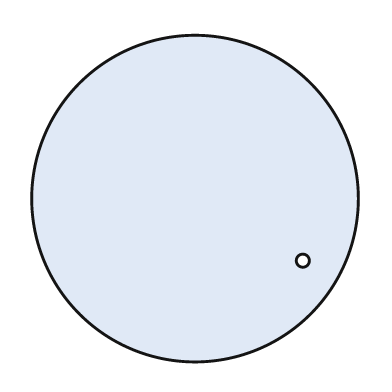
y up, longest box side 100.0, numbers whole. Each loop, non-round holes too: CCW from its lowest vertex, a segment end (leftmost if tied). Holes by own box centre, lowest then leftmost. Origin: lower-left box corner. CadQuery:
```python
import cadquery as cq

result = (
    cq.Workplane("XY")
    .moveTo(50.0, 50.0)
    .circle(50.0)
    .moveTo(83.0, 31.0)
    .circle(2.0)
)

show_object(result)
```